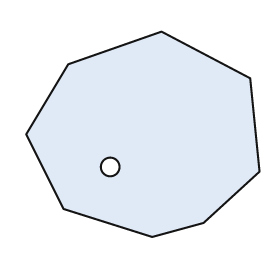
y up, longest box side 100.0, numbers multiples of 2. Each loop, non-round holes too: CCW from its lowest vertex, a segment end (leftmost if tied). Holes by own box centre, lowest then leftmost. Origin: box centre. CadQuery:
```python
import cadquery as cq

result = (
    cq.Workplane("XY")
    .moveTo(4.0, -44.0)
    .lineTo(26.0, -38.0)
    .lineTo(50.0, -16.0)
    .lineTo(46.0, 24.0)
    .lineTo(8.0, 44.0)
    .lineTo(-32.0, 30.0)
    .lineTo(-50.0, 0.0)
    .lineTo(-34.0, -32.0)
    .close()
    .moveTo(-14.0, -14.0)
    .circle(4.0)
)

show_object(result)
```